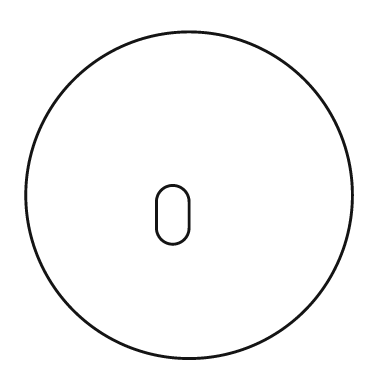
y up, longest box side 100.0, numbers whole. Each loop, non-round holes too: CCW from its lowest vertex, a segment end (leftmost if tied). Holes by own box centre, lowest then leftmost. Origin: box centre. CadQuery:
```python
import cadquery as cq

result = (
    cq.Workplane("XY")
    .moveTo(0.0, 0.0)
    .circle(50.0)
    .moveTo(-10.0, -10.0)
    .threePointArc((-5.0, -15.0), (0.0, -10.0))
    .lineTo(0.0, -2.0)
    .threePointArc((-5.0, 3.0), (-10.0, -2.0))
    .close()
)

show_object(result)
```